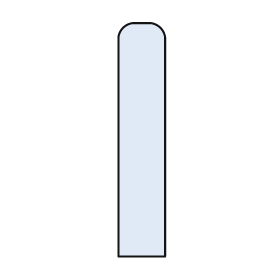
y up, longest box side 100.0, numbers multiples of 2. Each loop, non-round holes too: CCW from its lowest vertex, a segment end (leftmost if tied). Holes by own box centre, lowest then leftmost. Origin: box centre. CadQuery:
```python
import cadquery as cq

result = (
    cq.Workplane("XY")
    .moveTo(-10.0, -50.0)
    .lineTo(10.0, -50.0)
    .lineTo(10.0, 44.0)
    .threePointArc((8.0, 48.0), (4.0, 50.0))
    .lineTo(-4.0, 50.0)
    .threePointArc((-8.0, 48.0), (-10.0, 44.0))
    .close()
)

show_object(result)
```